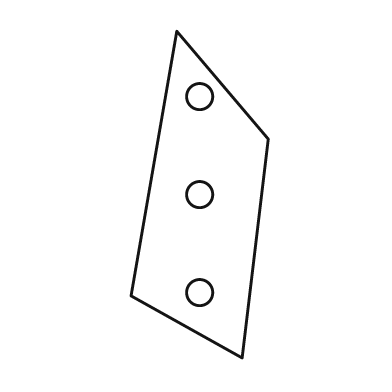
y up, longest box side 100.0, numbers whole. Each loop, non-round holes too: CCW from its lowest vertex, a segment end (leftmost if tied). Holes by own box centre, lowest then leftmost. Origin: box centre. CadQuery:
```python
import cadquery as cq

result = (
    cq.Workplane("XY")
    .moveTo(13.0, -50.0)
    .lineTo(21.0, 17.0)
    .lineTo(-7.0, 50.0)
    .lineTo(-21.0, -31.0)
    .close()
    .moveTo(0.0, -30.0)
    .circle(4.0)
    .moveTo(0.0, 0.0)
    .circle(4.0)
    .moveTo(0.0, 30.0)
    .circle(4.0)
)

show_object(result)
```